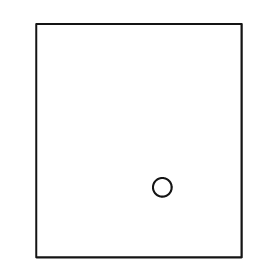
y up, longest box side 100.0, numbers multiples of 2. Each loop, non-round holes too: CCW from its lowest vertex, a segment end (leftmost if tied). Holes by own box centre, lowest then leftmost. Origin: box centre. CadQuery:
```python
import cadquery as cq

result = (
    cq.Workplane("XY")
    .moveTo(-44.0, -50.0)
    .lineTo(44.0, -50.0)
    .lineTo(44.0, 50.0)
    .lineTo(-44.0, 50.0)
    .close()
    .moveTo(10.0, -20.0)
    .circle(4.0)
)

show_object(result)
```